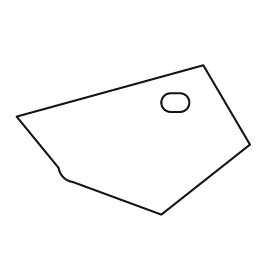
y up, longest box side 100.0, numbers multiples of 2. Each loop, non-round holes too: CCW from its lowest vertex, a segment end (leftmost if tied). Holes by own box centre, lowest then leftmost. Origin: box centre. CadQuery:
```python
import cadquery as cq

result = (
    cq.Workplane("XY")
    .moveTo(12.0, -32.0)
    .lineTo(50.0, -2.0)
    .lineTo(30.0, 32.0)
    .lineTo(-50.0, 10.0)
    .lineTo(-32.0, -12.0)
    .threePointArc((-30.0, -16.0), (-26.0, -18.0))
    .close()
    .moveTo(16.0, 12.0)
    .lineTo(20.0, 12.0)
    .threePointArc((24.0, 16.0), (20.0, 20.0))
    .lineTo(16.0, 20.0)
    .threePointArc((12.0, 16.0), (16.0, 12.0))
    .close()
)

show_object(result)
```